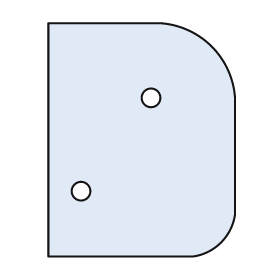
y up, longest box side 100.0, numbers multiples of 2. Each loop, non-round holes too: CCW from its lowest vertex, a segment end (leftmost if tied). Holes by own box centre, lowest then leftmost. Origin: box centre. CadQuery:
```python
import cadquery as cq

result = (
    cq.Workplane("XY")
    .moveTo(-40.0, -50.0)
    .lineTo(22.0, -50.0)
    .threePointArc((34.0, -44.0), (40.0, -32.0))
    .lineTo(40.0, 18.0)
    .threePointArc((30.0, 40.0), (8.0, 50.0))
    .lineTo(-40.0, 50.0)
    .close()
    .moveTo(-26.0, -22.0)
    .circle(4.0)
    .moveTo(4.0, 18.0)
    .circle(4.0)
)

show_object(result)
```